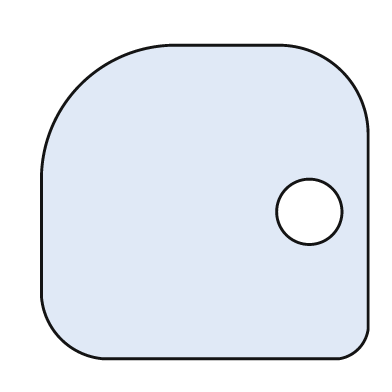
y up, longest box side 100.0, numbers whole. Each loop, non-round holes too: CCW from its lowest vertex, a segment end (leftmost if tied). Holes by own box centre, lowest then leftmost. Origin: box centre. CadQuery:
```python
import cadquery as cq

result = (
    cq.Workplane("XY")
    .moveTo(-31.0, -48.0)
    .lineTo(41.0, -48.0)
    .threePointArc((47.0, -45.0), (50.0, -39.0))
    .lineTo(50.0, 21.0)
    .threePointArc((42.0, 40.0), (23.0, 48.0))
    .lineTo(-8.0, 48.0)
    .threePointArc((-38.0, 36.0), (-50.0, 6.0))
    .lineTo(-50.0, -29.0)
    .threePointArc((-44.0, -42.0), (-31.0, -48.0))
    .close()
    .moveTo(32.0, -3.0)
    .circle(10.0)
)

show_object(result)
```